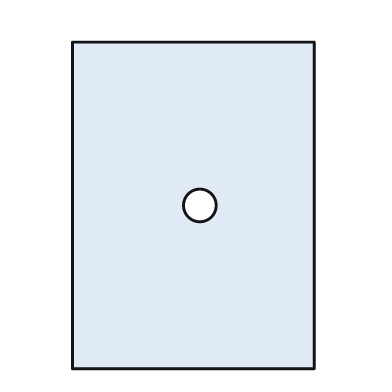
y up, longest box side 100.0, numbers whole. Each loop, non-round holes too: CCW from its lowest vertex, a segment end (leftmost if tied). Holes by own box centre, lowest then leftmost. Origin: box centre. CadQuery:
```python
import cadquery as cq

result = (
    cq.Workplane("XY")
    .moveTo(-37.0, -50.0)
    .lineTo(37.0, -50.0)
    .lineTo(37.0, 50.0)
    .lineTo(-37.0, 50.0)
    .close()
    .moveTo(2.0, 0.0)
    .circle(5.0)
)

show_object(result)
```